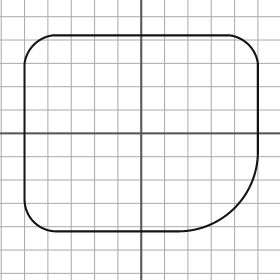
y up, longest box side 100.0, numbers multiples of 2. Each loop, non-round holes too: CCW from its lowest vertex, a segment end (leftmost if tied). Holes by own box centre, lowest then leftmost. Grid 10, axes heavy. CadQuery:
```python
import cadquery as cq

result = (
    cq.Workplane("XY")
    .moveTo(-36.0, -42.0)
    .lineTo(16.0, -42.0)
    .threePointArc((40.0, -32.0), (50.0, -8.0))
    .lineTo(50.0, 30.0)
    .threePointArc((46.0, 38.0), (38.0, 42.0))
    .lineTo(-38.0, 42.0)
    .threePointArc((-46.0, 38.0), (-50.0, 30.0))
    .lineTo(-50.0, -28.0)
    .threePointArc((-46.0, -38.0), (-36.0, -42.0))
    .close()
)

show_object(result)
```